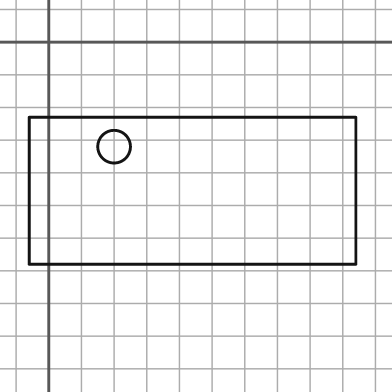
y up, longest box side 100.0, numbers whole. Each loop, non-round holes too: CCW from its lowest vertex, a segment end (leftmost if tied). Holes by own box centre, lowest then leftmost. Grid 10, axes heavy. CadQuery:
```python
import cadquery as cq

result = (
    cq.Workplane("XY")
    .moveTo(-6.0, -68.0)
    .lineTo(94.0, -68.0)
    .lineTo(94.0, -23.0)
    .lineTo(-6.0, -23.0)
    .close()
    .moveTo(20.0, -32.0)
    .circle(5.0)
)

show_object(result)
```